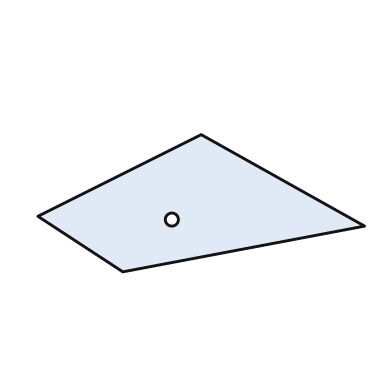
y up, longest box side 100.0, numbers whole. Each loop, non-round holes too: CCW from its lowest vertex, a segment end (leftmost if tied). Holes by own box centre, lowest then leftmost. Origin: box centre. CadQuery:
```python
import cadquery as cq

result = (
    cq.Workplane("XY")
    .moveTo(-24.0, -21.0)
    .lineTo(50.0, -7.0)
    .lineTo(0.0, 21.0)
    .lineTo(-50.0, -4.0)
    .close()
    .moveTo(-9.0, -5.0)
    .circle(2.0)
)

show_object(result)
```